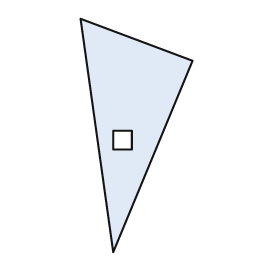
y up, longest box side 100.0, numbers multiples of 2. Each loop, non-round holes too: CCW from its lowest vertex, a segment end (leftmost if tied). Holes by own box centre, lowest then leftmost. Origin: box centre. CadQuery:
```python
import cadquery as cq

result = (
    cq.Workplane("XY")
    .moveTo(-10.0, -50.0)
    .lineTo(24.0, 32.0)
    .lineTo(-24.0, 50.0)
    .close()
    .moveTo(-10.0, -6.0)
    .lineTo(-2.0, -6.0)
    .lineTo(-2.0, 2.0)
    .lineTo(-10.0, 2.0)
    .close()
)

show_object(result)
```